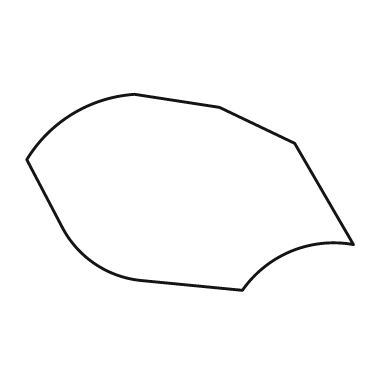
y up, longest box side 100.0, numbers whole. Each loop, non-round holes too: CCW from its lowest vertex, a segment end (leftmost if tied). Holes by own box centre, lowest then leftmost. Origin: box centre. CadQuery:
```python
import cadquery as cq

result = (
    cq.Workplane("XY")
    .moveTo(16.0, -30.0)
    .threePointArc((31.0, -18.0), (50.0, -16.0))
    .lineTo(32.0, 15.0)
    .lineTo(9.0, 26.0)
    .lineTo(-17.0, 30.0)
    .threePointArc((-36.0, 24.0), (-50.0, 10.0))
    .lineTo(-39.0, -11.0)
    .threePointArc((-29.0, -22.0), (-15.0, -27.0))
    .close()
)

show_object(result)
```